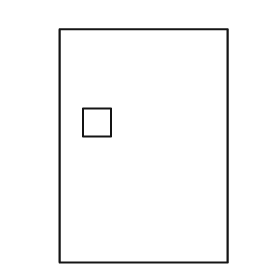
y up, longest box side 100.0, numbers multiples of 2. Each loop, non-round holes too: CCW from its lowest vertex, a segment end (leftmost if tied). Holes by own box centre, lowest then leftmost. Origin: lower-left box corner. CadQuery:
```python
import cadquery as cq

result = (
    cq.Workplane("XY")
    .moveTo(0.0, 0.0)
    .lineTo(72.0, 0.0)
    .lineTo(72.0, 100.0)
    .lineTo(0.0, 100.0)
    .close()
    .moveTo(10.0, 54.0)
    .lineTo(22.0, 54.0)
    .lineTo(22.0, 66.0)
    .lineTo(10.0, 66.0)
    .close()
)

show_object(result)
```